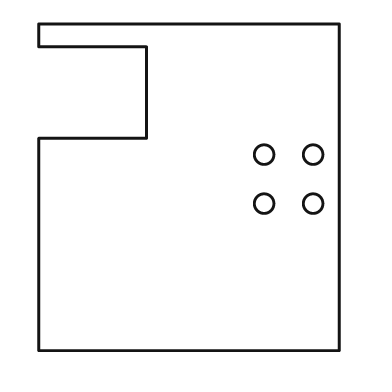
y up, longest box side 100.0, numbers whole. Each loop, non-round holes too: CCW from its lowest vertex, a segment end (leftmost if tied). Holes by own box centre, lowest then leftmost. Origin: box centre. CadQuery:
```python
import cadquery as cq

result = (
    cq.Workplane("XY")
    .moveTo(-46.0, -50.0)
    .lineTo(46.0, -50.0)
    .lineTo(46.0, 50.0)
    .lineTo(-46.0, 50.0)
    .lineTo(-46.0, 43.0)
    .lineTo(-13.0, 43.0)
    .lineTo(-13.0, 15.0)
    .lineTo(-46.0, 15.0)
    .close()
    .moveTo(23.0, -5.0)
    .circle(3.0)
    .moveTo(38.0, -5.0)
    .circle(3.0)
    .moveTo(23.0, 10.0)
    .circle(3.0)
    .moveTo(38.0, 10.0)
    .circle(3.0)
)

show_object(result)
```